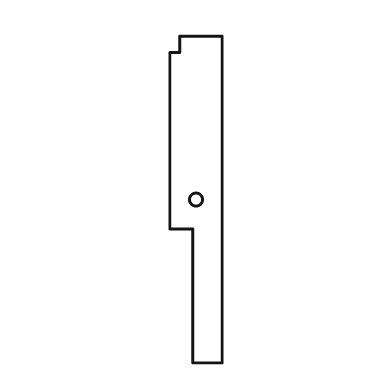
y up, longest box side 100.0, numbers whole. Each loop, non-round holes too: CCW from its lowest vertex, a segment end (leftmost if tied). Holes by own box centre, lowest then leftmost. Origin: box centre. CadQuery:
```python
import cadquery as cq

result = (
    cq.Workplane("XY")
    .moveTo(-1.0, -50.0)
    .lineTo(8.0, -50.0)
    .lineTo(8.0, 50.0)
    .lineTo(-5.0, 50.0)
    .lineTo(-5.0, 45.0)
    .lineTo(-8.0, 45.0)
    .lineTo(-8.0, -9.0)
    .lineTo(-1.0, -9.0)
    .close()
    .moveTo(0.0, 0.0)
    .circle(2.0)
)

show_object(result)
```